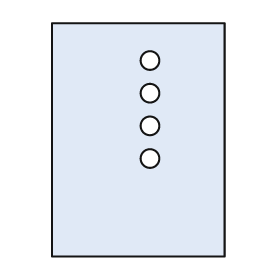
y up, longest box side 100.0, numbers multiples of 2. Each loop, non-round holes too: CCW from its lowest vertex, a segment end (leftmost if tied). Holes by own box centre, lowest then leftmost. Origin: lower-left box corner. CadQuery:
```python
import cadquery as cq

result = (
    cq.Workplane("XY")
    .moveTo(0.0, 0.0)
    .lineTo(74.0, 0.0)
    .lineTo(74.0, 100.0)
    .lineTo(0.0, 100.0)
    .close()
    .moveTo(42.0, 42.0)
    .circle(4.0)
    .moveTo(42.0, 56.0)
    .circle(4.0)
    .moveTo(42.0, 70.0)
    .circle(4.0)
    .moveTo(42.0, 84.0)
    .circle(4.0)
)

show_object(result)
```